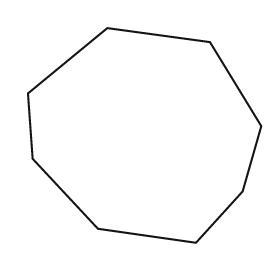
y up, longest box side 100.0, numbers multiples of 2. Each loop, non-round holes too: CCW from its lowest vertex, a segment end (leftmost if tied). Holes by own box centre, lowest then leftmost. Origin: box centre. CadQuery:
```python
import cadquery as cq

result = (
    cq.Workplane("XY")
    .moveTo(22.0, -46.0)
    .lineTo(42.0, -24.0)
    .lineTo(50.0, 4.0)
    .lineTo(28.0, 40.0)
    .lineTo(-16.0, 46.0)
    .lineTo(-50.0, 18.0)
    .lineTo(-48.0, -10.0)
    .lineTo(-20.0, -40.0)
    .close()
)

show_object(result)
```